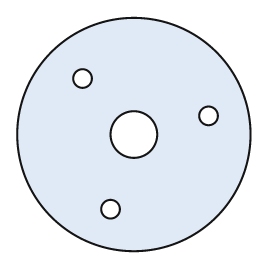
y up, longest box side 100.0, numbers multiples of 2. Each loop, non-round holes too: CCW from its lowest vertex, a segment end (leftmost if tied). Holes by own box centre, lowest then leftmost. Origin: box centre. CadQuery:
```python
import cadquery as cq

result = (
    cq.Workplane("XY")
    .moveTo(0.0, 0.0)
    .circle(50.0)
    .moveTo(-10.0, -32.0)
    .circle(4.0)
    .moveTo(0.0, 0.0)
    .circle(10.0)
    .moveTo(32.0, 8.0)
    .circle(4.0)
    .moveTo(-22.0, 24.0)
    .circle(4.0)
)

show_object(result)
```